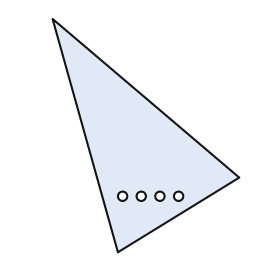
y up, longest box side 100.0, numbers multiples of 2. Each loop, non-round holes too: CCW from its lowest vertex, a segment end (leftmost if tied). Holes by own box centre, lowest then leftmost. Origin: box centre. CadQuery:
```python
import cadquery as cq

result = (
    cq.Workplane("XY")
    .moveTo(-12.0, -50.0)
    .lineTo(40.0, -18.0)
    .lineTo(-40.0, 50.0)
    .close()
    .moveTo(-10.0, -26.0)
    .circle(2.0)
    .moveTo(-2.0, -26.0)
    .circle(2.0)
    .moveTo(6.0, -26.0)
    .circle(2.0)
    .moveTo(14.0, -26.0)
    .circle(2.0)
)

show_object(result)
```